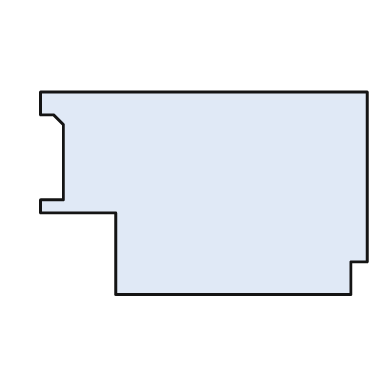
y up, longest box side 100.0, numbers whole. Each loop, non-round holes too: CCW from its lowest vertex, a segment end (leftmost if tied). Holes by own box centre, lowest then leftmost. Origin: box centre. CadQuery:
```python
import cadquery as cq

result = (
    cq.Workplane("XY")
    .moveTo(-27.0, -31.0)
    .lineTo(45.0, -31.0)
    .lineTo(45.0, -21.0)
    .lineTo(50.0, -21.0)
    .lineTo(50.0, 31.0)
    .lineTo(-50.0, 31.0)
    .lineTo(-50.0, 24.0)
    .lineTo(-46.0, 24.0)
    .lineTo(-43.0, 21.0)
    .lineTo(-43.0, -2.0)
    .lineTo(-50.0, -2.0)
    .lineTo(-50.0, -6.0)
    .lineTo(-27.0, -6.0)
    .close()
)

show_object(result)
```